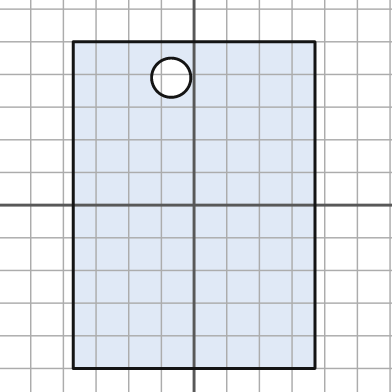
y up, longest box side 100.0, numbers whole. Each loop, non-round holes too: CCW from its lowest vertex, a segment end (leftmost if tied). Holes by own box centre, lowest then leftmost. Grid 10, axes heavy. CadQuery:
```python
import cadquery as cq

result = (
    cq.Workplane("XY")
    .moveTo(-37.0, -50.0)
    .lineTo(37.0, -50.0)
    .lineTo(37.0, 50.0)
    .lineTo(-37.0, 50.0)
    .close()
    .moveTo(-7.0, 39.0)
    .circle(6.0)
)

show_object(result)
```